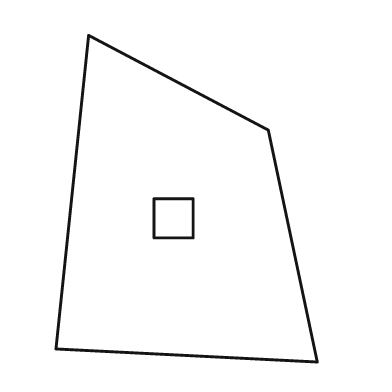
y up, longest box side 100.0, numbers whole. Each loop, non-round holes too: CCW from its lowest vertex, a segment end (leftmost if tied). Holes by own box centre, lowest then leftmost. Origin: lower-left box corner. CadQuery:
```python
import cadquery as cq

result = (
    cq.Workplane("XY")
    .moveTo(80.0, 0.0)
    .lineTo(65.0, 71.0)
    .lineTo(10.0, 100.0)
    .lineTo(0.0, 4.0)
    .close()
    .moveTo(30.0, 38.0)
    .lineTo(42.0, 38.0)
    .lineTo(42.0, 50.0)
    .lineTo(30.0, 50.0)
    .close()
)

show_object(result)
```